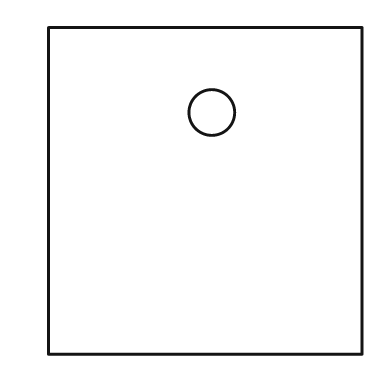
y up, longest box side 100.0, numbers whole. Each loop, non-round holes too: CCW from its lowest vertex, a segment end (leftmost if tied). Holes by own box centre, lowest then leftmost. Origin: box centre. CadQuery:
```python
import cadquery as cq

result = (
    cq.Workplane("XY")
    .moveTo(-48.0, -50.0)
    .lineTo(48.0, -50.0)
    .lineTo(48.0, 50.0)
    .lineTo(-48.0, 50.0)
    .close()
    .moveTo(2.0, 24.0)
    .circle(7.0)
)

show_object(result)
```